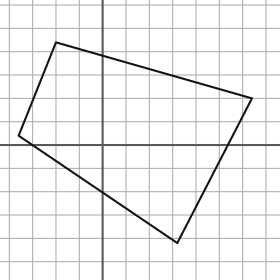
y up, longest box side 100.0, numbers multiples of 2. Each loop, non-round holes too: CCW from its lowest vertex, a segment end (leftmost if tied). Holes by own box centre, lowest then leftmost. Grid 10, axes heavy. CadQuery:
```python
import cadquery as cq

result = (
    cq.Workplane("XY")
    .moveTo(32.0, -42.0)
    .lineTo(64.0, 20.0)
    .lineTo(-20.0, 44.0)
    .lineTo(-36.0, 4.0)
    .close()
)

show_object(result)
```